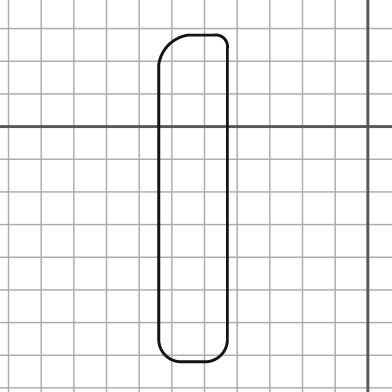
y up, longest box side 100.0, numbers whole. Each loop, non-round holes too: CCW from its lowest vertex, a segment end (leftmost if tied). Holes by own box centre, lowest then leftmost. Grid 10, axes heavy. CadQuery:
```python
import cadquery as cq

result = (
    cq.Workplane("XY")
    .moveTo(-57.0, -72.0)
    .lineTo(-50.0, -72.0)
    .threePointArc((-45.0, -70.0), (-43.0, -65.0))
    .lineTo(-43.0, 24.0)
    .threePointArc((-44.0, 27.0), (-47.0, 28.0))
    .lineTo(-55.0, 28.0)
    .threePointArc((-61.0, 25.0), (-64.0, 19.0))
    .lineTo(-64.0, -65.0)
    .threePointArc((-62.0, -70.0), (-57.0, -72.0))
    .close()
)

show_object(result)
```